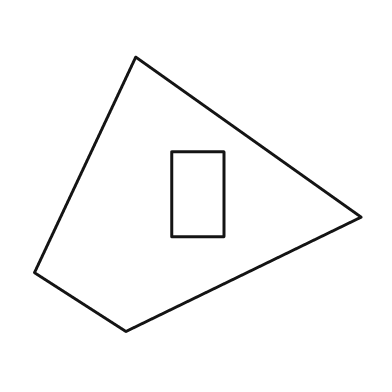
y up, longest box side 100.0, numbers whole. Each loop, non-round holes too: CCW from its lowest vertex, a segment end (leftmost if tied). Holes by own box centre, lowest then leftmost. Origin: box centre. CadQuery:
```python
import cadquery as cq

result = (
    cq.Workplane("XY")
    .moveTo(-22.0, -42.0)
    .lineTo(50.0, -7.0)
    .lineTo(-19.0, 42.0)
    .lineTo(-50.0, -24.0)
    .close()
    .moveTo(-8.0, -13.0)
    .lineTo(8.0, -13.0)
    .lineTo(8.0, 13.0)
    .lineTo(-8.0, 13.0)
    .close()
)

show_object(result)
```